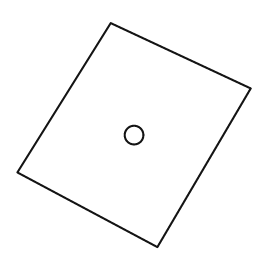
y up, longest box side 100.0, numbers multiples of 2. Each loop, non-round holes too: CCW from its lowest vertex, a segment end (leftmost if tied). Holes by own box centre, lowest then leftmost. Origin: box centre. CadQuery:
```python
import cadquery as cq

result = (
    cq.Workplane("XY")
    .moveTo(10.0, -48.0)
    .lineTo(50.0, 20.0)
    .lineTo(-10.0, 48.0)
    .lineTo(-50.0, -16.0)
    .close()
    .moveTo(0.0, 0.0)
    .circle(4.0)
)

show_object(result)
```